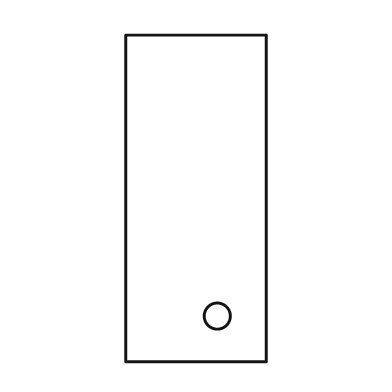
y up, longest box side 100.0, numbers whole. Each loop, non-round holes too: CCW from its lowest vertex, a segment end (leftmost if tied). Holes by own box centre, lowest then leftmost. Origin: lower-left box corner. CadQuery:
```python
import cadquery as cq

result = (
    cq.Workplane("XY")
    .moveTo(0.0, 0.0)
    .lineTo(43.0, 0.0)
    .lineTo(43.0, 100.0)
    .lineTo(0.0, 100.0)
    .close()
    .moveTo(28.0, 14.0)
    .circle(4.0)
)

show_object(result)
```